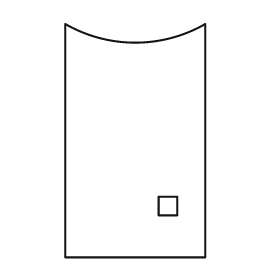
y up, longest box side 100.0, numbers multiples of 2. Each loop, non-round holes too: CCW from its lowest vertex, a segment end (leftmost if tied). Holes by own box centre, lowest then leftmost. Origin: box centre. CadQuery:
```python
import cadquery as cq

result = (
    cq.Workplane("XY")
    .moveTo(-30.0, -50.0)
    .lineTo(30.0, -50.0)
    .lineTo(30.0, 50.0)
    .threePointArc((0.0, 42.0), (-30.0, 50.0))
    .close()
    .moveTo(10.0, -32.0)
    .lineTo(18.0, -32.0)
    .lineTo(18.0, -24.0)
    .lineTo(10.0, -24.0)
    .close()
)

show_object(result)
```